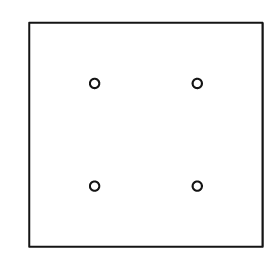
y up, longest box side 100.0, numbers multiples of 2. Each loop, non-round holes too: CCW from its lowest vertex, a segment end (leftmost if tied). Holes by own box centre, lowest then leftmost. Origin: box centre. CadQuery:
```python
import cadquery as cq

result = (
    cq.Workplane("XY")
    .moveTo(-50.0, -48.0)
    .lineTo(50.0, -48.0)
    .lineTo(50.0, 48.0)
    .lineTo(-50.0, 48.0)
    .close()
    .moveTo(-22.0, -22.0)
    .circle(2.0)
    .moveTo(22.0, -22.0)
    .circle(2.0)
    .moveTo(-22.0, 22.0)
    .circle(2.0)
    .moveTo(22.0, 22.0)
    .circle(2.0)
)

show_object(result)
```